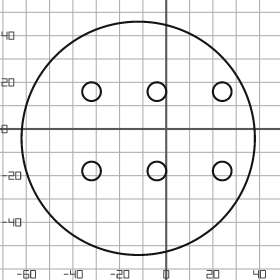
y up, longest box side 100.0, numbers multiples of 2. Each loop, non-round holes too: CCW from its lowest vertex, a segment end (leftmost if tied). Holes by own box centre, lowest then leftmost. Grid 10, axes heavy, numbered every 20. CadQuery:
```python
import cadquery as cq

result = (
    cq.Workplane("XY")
    .moveTo(-12.0, -4.0)
    .circle(50.0)
    .moveTo(-32.0, -18.0)
    .circle(4.0)
    .moveTo(-4.0, -18.0)
    .circle(4.0)
    .moveTo(24.0, -18.0)
    .circle(4.0)
    .moveTo(-32.0, 16.0)
    .circle(4.0)
    .moveTo(-4.0, 16.0)
    .circle(4.0)
    .moveTo(24.0, 16.0)
    .circle(4.0)
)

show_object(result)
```